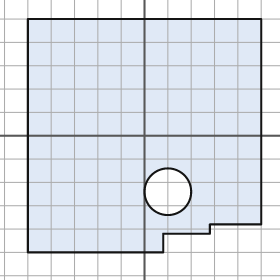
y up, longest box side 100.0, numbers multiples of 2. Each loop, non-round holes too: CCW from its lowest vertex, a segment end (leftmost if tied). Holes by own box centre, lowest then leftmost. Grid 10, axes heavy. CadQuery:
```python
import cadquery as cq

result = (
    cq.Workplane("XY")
    .moveTo(-50.0, -50.0)
    .lineTo(8.0, -50.0)
    .lineTo(8.0, -42.0)
    .lineTo(28.0, -42.0)
    .lineTo(28.0, -38.0)
    .lineTo(50.0, -38.0)
    .lineTo(50.0, 50.0)
    .lineTo(-50.0, 50.0)
    .close()
    .moveTo(10.0, -24.0)
    .circle(10.0)
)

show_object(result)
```